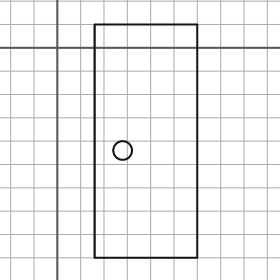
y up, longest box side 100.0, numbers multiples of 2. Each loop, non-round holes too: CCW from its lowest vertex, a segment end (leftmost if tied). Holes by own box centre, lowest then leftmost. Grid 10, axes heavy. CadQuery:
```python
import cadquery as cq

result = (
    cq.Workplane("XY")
    .moveTo(16.0, -90.0)
    .lineTo(60.0, -90.0)
    .lineTo(60.0, 10.0)
    .lineTo(16.0, 10.0)
    .close()
    .moveTo(28.0, -44.0)
    .circle(4.0)
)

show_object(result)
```